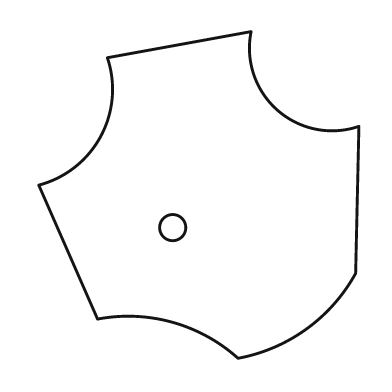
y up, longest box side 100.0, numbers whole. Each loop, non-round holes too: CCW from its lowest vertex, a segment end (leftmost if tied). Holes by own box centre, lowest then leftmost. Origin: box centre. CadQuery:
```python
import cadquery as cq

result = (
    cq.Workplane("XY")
    .moveTo(12.0, -50.0)
    .threePointArc((33.0, -41.0), (48.0, -24.0))
    .lineTo(49.0, 21.0)
    .threePointArc((24.0, 26.0), (16.0, 50.0))
    .lineTo(-28.0, 42.0)
    .threePointArc((-30.0, 18.0), (-49.0, 3.0))
    .lineTo(-31.0, -38.0)
    .threePointArc((-8.0, -39.0), (12.0, -50.0))
    .close()
    .moveTo(-8.0, -10.0)
    .circle(4.0)
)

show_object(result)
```